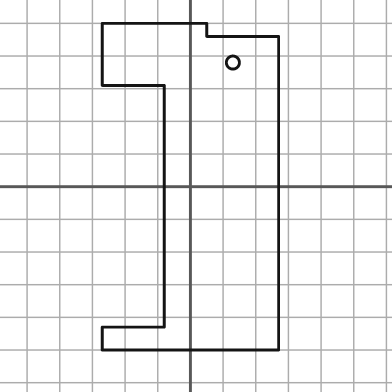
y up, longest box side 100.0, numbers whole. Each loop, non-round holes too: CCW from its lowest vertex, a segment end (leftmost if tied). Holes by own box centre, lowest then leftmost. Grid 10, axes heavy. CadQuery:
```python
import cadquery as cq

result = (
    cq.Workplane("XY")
    .moveTo(-27.0, -50.0)
    .lineTo(27.0, -50.0)
    .lineTo(27.0, 46.0)
    .lineTo(5.0, 46.0)
    .lineTo(5.0, 50.0)
    .lineTo(-27.0, 50.0)
    .lineTo(-27.0, 31.0)
    .lineTo(-8.0, 31.0)
    .lineTo(-8.0, -43.0)
    .lineTo(-27.0, -43.0)
    .close()
    .moveTo(13.0, 38.0)
    .circle(2.0)
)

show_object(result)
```